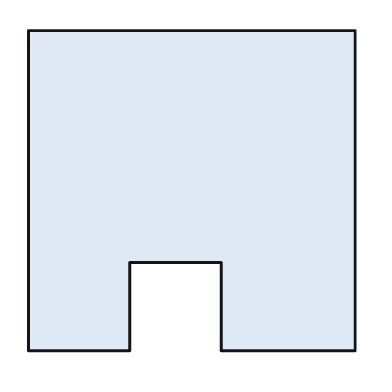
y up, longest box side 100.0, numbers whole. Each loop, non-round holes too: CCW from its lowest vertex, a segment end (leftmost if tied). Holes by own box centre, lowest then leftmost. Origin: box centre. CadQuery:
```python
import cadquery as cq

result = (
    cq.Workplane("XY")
    .moveTo(-50.0, -49.0)
    .lineTo(-19.0, -49.0)
    .lineTo(-19.0, -22.0)
    .lineTo(9.0, -22.0)
    .lineTo(9.0, -49.0)
    .lineTo(50.0, -49.0)
    .lineTo(50.0, 49.0)
    .lineTo(-50.0, 49.0)
    .close()
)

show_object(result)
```